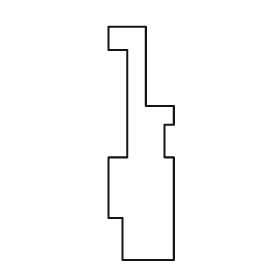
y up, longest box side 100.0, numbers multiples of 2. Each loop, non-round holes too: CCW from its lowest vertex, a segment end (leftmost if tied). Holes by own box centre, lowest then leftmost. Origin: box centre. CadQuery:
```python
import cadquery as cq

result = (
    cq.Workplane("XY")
    .moveTo(-8.0, -50.0)
    .lineTo(14.0, -50.0)
    .lineTo(14.0, -6.0)
    .lineTo(10.0, -6.0)
    .lineTo(10.0, 8.0)
    .lineTo(14.0, 8.0)
    .lineTo(14.0, 16.0)
    .lineTo(2.0, 16.0)
    .lineTo(2.0, 50.0)
    .lineTo(-14.0, 50.0)
    .lineTo(-14.0, 40.0)
    .lineTo(-6.0, 40.0)
    .lineTo(-6.0, -6.0)
    .lineTo(-14.0, -6.0)
    .lineTo(-14.0, -32.0)
    .lineTo(-8.0, -32.0)
    .close()
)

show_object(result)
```